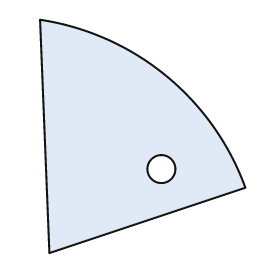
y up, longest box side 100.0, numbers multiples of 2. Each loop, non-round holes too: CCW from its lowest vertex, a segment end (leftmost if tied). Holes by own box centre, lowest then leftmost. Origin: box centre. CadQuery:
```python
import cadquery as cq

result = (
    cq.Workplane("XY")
    .moveTo(-40.0, -50.0)
    .lineTo(44.0, -22.0)
    .threePointArc((10.0, 26.0), (-44.0, 50.0))
    .close()
    .moveTo(8.0, -14.0)
    .circle(6.0)
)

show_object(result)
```